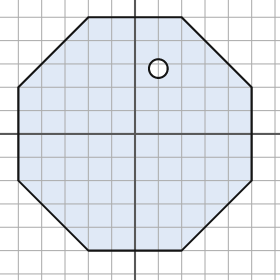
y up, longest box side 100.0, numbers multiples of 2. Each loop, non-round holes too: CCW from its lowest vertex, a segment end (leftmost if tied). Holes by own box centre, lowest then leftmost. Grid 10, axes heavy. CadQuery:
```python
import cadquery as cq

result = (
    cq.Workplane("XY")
    .moveTo(-20.0, -50.0)
    .lineTo(20.0, -50.0)
    .lineTo(50.0, -20.0)
    .lineTo(50.0, 20.0)
    .lineTo(20.0, 50.0)
    .lineTo(-20.0, 50.0)
    .lineTo(-50.0, 20.0)
    .lineTo(-50.0, -20.0)
    .close()
    .moveTo(10.0, 28.0)
    .circle(4.0)
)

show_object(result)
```